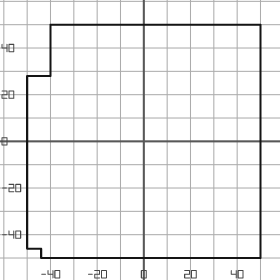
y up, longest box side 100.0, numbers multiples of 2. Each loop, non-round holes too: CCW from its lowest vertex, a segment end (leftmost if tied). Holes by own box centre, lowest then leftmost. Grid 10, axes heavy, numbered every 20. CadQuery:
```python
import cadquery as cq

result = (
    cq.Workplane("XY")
    .moveTo(-44.0, -50.0)
    .lineTo(50.0, -50.0)
    .lineTo(50.0, 50.0)
    .lineTo(-40.0, 50.0)
    .lineTo(-40.0, 28.0)
    .lineTo(-50.0, 28.0)
    .lineTo(-50.0, -46.0)
    .lineTo(-44.0, -46.0)
    .close()
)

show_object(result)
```